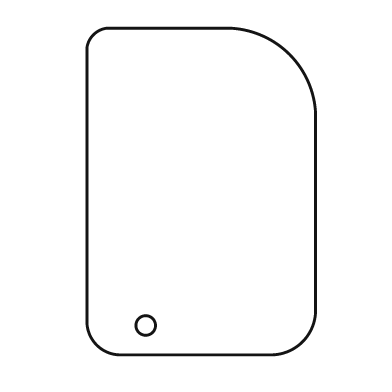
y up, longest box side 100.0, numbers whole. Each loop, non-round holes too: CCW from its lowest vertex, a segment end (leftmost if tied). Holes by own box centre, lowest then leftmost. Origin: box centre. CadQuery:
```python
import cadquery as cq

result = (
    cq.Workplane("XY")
    .moveTo(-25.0, -50.0)
    .lineTo(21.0, -50.0)
    .threePointArc((31.0, -46.0), (35.0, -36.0))
    .lineTo(35.0, 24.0)
    .threePointArc((27.0, 42.0), (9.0, 50.0))
    .lineTo(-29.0, 50.0)
    .threePointArc((-33.0, 48.0), (-35.0, 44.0))
    .lineTo(-35.0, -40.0)
    .threePointArc((-32.0, -47.0), (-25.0, -50.0))
    .close()
    .moveTo(-17.0, -41.0)
    .circle(3.0)
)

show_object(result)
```